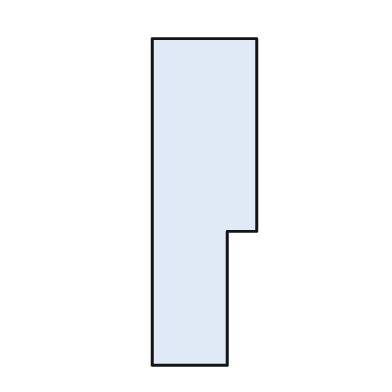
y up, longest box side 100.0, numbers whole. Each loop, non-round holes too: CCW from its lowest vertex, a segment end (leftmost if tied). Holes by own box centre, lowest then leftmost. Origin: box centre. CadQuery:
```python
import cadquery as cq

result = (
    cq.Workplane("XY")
    .moveTo(-16.0, -50.0)
    .lineTo(7.0, -50.0)
    .lineTo(7.0, -9.0)
    .lineTo(16.0, -9.0)
    .lineTo(16.0, 50.0)
    .lineTo(-16.0, 50.0)
    .close()
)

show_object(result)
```